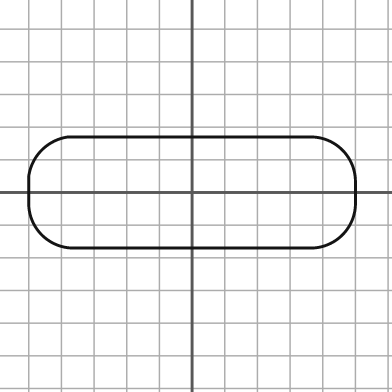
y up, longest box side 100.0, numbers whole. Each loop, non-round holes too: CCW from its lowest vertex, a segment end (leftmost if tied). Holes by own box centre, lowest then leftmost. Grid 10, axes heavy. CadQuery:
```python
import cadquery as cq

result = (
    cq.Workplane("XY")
    .moveTo(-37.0, -17.0)
    .lineTo(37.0, -17.0)
    .threePointArc((46.0, -13.0), (50.0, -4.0))
    .lineTo(50.0, 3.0)
    .threePointArc((46.0, 13.0), (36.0, 17.0))
    .lineTo(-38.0, 17.0)
    .threePointArc((-46.0, 13.0), (-50.0, 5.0))
    .lineTo(-50.0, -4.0)
    .threePointArc((-46.0, -13.0), (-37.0, -17.0))
    .close()
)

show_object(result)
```